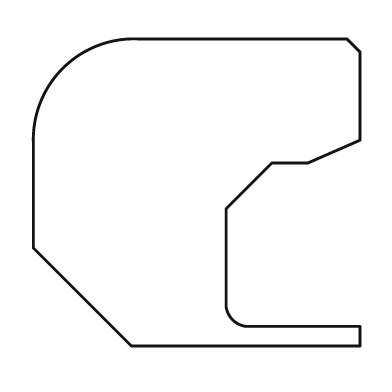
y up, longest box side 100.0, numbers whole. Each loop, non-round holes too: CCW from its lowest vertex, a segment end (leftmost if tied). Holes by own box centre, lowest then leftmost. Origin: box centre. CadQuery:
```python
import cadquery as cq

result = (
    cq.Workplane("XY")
    .moveTo(-20.0, -47.0)
    .lineTo(50.0, -47.0)
    .lineTo(50.0, -41.0)
    .lineTo(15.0, -41.0)
    .threePointArc((11.0, -39.0), (9.0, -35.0))
    .lineTo(9.0, -5.0)
    .lineTo(23.0, 9.0)
    .lineTo(34.0, 9.0)
    .lineTo(50.0, 16.0)
    .lineTo(50.0, 43.0)
    .lineTo(46.0, 47.0)
    .lineTo(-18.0, 47.0)
    .threePointArc((-41.0, 38.0), (-50.0, 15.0))
    .lineTo(-50.0, -17.0)
    .close()
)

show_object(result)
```